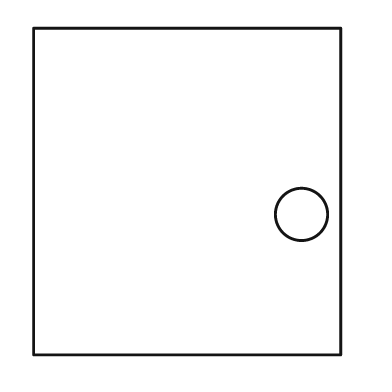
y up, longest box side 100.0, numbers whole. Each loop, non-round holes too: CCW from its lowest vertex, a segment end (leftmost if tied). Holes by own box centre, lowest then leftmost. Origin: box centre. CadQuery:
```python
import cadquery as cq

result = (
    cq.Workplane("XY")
    .moveTo(-47.0, -50.0)
    .lineTo(47.0, -50.0)
    .lineTo(47.0, 50.0)
    .lineTo(-47.0, 50.0)
    .close()
    .moveTo(35.0, -7.0)
    .circle(8.0)
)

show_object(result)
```